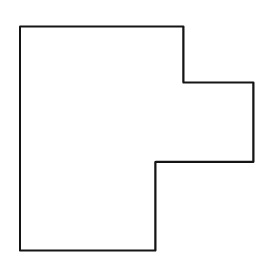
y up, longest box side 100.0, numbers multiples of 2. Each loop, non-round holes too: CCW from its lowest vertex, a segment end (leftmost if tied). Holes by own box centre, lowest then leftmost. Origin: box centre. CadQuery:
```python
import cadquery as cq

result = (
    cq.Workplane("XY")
    .moveTo(-50.0, -48.0)
    .lineTo(8.0, -48.0)
    .lineTo(8.0, -10.0)
    .lineTo(50.0, -10.0)
    .lineTo(50.0, 24.0)
    .lineTo(20.0, 24.0)
    .lineTo(20.0, 48.0)
    .lineTo(-50.0, 48.0)
    .close()
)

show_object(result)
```